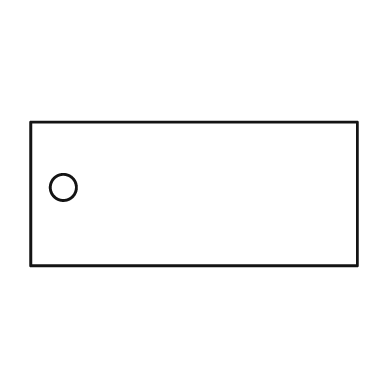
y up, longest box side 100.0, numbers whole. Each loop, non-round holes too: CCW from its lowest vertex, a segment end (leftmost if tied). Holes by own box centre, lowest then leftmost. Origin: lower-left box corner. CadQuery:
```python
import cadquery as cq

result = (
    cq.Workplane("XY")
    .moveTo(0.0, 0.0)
    .lineTo(100.0, 0.0)
    .lineTo(100.0, 44.0)
    .lineTo(0.0, 44.0)
    .close()
    .moveTo(10.0, 24.0)
    .circle(4.0)
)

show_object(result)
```